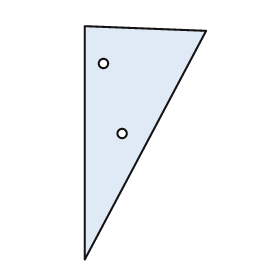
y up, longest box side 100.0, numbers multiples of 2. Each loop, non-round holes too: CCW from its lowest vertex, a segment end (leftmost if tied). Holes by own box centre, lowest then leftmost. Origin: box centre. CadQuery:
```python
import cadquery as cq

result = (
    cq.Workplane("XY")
    .moveTo(-26.0, -50.0)
    .lineTo(26.0, 48.0)
    .lineTo(-26.0, 50.0)
    .close()
    .moveTo(-10.0, 4.0)
    .circle(2.0)
    .moveTo(-18.0, 34.0)
    .circle(2.0)
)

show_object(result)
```